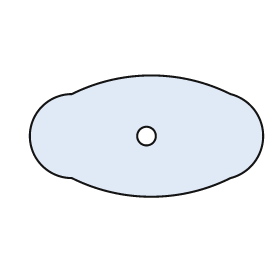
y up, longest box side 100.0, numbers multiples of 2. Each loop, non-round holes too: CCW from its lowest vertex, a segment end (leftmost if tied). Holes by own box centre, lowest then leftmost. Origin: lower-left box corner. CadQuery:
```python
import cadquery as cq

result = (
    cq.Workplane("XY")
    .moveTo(18.0, 8.0)
    .threePointArc((52.0, 0.0), (86.0, 8.0))
    .threePointArc((100.0, 26.0), (86.0, 44.0))
    .threePointArc((52.0, 52.0), (18.0, 44.0))
    .threePointArc((0.0, 26.0), (18.0, 8.0))
    .close()
    .moveTo(50.0, 26.0)
    .circle(4.0)
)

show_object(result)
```